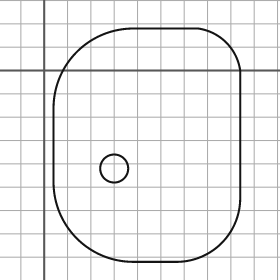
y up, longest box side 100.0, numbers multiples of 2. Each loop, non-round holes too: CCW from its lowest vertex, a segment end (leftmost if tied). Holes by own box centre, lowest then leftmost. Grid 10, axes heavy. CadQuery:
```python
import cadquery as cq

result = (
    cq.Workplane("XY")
    .moveTo(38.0, -82.0)
    .lineTo(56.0, -82.0)
    .threePointArc((76.0, -74.0), (84.0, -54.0))
    .lineTo(84.0, 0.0)
    .threePointArc((78.0, 12.0), (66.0, 18.0))
    .lineTo(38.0, 18.0)
    .threePointArc((14.0, 8.0), (4.0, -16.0))
    .lineTo(4.0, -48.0)
    .threePointArc((14.0, -72.0), (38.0, -82.0))
    .close()
    .moveTo(30.0, -42.0)
    .circle(6.0)
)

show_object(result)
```